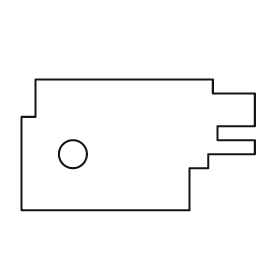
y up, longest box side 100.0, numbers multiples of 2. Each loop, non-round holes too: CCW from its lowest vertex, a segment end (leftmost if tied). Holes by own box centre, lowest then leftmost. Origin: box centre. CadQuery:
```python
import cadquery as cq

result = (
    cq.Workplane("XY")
    .moveTo(-50.0, -28.0)
    .lineTo(22.0, -28.0)
    .lineTo(22.0, -10.0)
    .lineTo(30.0, -10.0)
    .lineTo(30.0, -4.0)
    .lineTo(50.0, -4.0)
    .lineTo(50.0, 2.0)
    .lineTo(34.0, 2.0)
    .lineTo(34.0, 8.0)
    .lineTo(50.0, 8.0)
    .lineTo(50.0, 22.0)
    .lineTo(32.0, 22.0)
    .lineTo(32.0, 28.0)
    .lineTo(-44.0, 28.0)
    .lineTo(-44.0, 12.0)
    .lineTo(-50.0, 12.0)
    .close()
    .moveTo(-28.0, -4.0)
    .circle(6.0)
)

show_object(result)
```